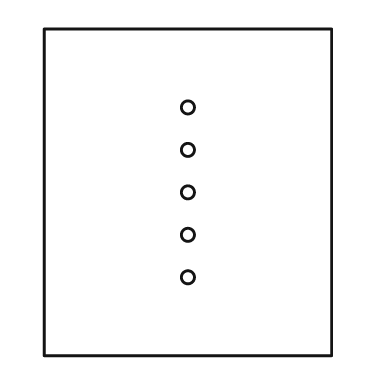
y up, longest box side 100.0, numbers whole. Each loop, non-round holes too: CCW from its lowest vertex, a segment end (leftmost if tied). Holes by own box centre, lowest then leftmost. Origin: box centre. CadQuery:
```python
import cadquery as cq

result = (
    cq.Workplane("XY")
    .moveTo(-44.0, -50.0)
    .lineTo(44.0, -50.0)
    .lineTo(44.0, 50.0)
    .lineTo(-44.0, 50.0)
    .close()
    .moveTo(0.0, -26.0)
    .circle(2.0)
    .moveTo(0.0, -13.0)
    .circle(2.0)
    .moveTo(0.0, 0.0)
    .circle(2.0)
    .moveTo(0.0, 13.0)
    .circle(2.0)
    .moveTo(0.0, 26.0)
    .circle(2.0)
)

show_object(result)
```